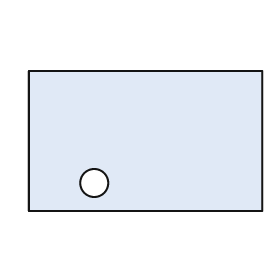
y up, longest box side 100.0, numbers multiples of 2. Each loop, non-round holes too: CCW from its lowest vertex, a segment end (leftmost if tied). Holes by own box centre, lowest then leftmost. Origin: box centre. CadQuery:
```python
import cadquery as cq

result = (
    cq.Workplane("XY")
    .moveTo(-50.0, -30.0)
    .lineTo(50.0, -30.0)
    .lineTo(50.0, 30.0)
    .lineTo(-50.0, 30.0)
    .close()
    .moveTo(-22.0, -18.0)
    .circle(6.0)
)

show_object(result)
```